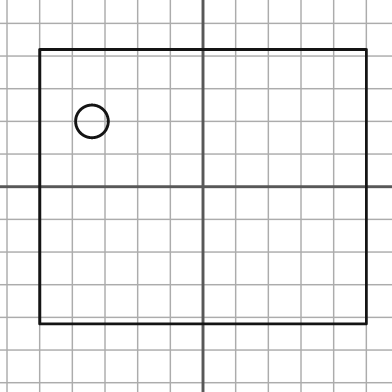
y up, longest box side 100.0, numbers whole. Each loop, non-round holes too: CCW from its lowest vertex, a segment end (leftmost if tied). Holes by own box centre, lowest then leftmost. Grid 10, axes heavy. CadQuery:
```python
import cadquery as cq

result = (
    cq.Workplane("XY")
    .moveTo(-50.0, -42.0)
    .lineTo(50.0, -42.0)
    .lineTo(50.0, 42.0)
    .lineTo(-50.0, 42.0)
    .close()
    .moveTo(-34.0, 20.0)
    .circle(5.0)
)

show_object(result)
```